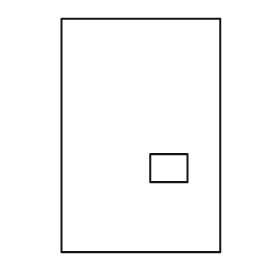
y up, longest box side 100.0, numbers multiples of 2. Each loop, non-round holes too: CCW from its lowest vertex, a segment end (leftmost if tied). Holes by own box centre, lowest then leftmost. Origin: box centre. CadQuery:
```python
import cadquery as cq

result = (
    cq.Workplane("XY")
    .moveTo(-34.0, -50.0)
    .lineTo(34.0, -50.0)
    .lineTo(34.0, 50.0)
    .lineTo(-34.0, 50.0)
    .close()
    .moveTo(4.0, -20.0)
    .lineTo(20.0, -20.0)
    .lineTo(20.0, -8.0)
    .lineTo(4.0, -8.0)
    .close()
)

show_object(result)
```